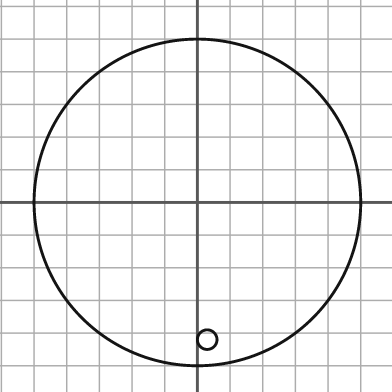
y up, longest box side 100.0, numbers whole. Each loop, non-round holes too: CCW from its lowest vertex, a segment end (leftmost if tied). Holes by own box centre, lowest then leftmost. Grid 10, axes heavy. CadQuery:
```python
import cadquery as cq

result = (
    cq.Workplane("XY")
    .moveTo(0.0, 0.0)
    .circle(50.0)
    .moveTo(3.0, -42.0)
    .circle(3.0)
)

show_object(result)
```